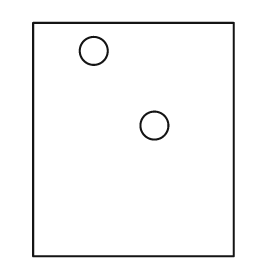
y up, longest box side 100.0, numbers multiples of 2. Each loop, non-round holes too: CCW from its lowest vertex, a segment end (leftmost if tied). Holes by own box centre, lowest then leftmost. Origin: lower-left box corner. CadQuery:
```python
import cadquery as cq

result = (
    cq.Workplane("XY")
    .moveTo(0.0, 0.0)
    .lineTo(86.0, 0.0)
    .lineTo(86.0, 100.0)
    .lineTo(0.0, 100.0)
    .close()
    .moveTo(52.0, 56.0)
    .circle(6.0)
    .moveTo(26.0, 88.0)
    .circle(6.0)
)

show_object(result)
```